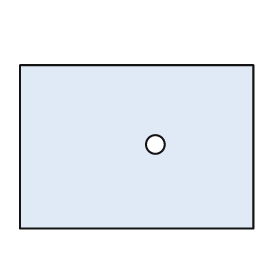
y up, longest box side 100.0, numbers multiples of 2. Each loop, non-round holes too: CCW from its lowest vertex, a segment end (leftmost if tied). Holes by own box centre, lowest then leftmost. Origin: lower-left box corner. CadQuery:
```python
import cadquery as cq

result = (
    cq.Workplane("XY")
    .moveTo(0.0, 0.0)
    .lineTo(100.0, 0.0)
    .lineTo(100.0, 70.0)
    .lineTo(0.0, 70.0)
    .close()
    .moveTo(58.0, 36.0)
    .circle(4.0)
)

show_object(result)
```